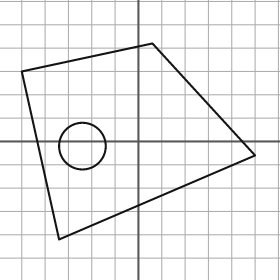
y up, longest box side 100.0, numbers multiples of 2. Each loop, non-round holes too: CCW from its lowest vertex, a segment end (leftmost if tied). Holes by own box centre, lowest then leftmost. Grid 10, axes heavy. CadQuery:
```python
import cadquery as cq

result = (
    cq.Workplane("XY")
    .moveTo(-34.0, -42.0)
    .lineTo(50.0, -6.0)
    .lineTo(6.0, 42.0)
    .lineTo(-50.0, 30.0)
    .close()
    .moveTo(-24.0, -2.0)
    .circle(10.0)
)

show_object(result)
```